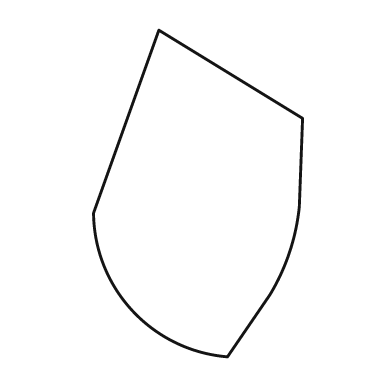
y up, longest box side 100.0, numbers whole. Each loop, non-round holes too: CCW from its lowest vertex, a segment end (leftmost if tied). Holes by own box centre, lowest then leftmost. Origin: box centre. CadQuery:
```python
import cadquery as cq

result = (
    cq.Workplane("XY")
    .moveTo(9.0, -50.0)
    .lineTo(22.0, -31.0)
    .threePointArc((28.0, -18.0), (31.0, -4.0))
    .lineTo(32.0, 23.0)
    .lineTo(-12.0, 50.0)
    .lineTo(-32.0, -6.0)
    .threePointArc((-20.0, -36.0), (9.0, -50.0))
    .close()
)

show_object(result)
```